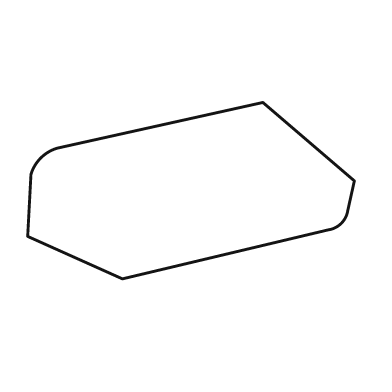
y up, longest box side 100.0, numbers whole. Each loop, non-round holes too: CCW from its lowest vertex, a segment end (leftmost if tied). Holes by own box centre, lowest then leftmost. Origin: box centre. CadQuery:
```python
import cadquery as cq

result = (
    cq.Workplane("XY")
    .moveTo(-21.0, -27.0)
    .lineTo(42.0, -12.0)
    .threePointArc((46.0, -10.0), (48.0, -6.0))
    .lineTo(50.0, 3.0)
    .lineTo(22.0, 27.0)
    .lineTo(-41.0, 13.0)
    .threePointArc((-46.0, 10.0), (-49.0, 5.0))
    .lineTo(-50.0, -14.0)
    .close()
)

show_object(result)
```